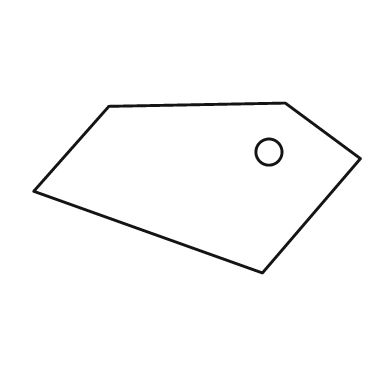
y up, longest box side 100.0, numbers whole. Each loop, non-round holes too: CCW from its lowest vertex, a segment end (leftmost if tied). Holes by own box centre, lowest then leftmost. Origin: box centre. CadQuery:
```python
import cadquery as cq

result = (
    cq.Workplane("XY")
    .moveTo(20.0, -26.0)
    .lineTo(50.0, 9.0)
    .lineTo(27.0, 26.0)
    .lineTo(-27.0, 25.0)
    .lineTo(-50.0, -1.0)
    .close()
    .moveTo(22.0, 11.0)
    .circle(4.0)
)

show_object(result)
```